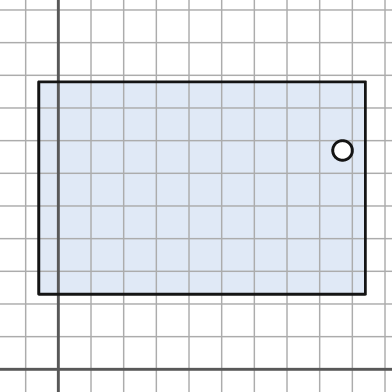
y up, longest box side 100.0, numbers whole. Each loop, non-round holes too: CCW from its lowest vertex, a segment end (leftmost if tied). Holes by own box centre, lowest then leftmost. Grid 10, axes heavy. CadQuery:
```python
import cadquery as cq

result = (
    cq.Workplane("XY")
    .moveTo(-6.0, 23.0)
    .lineTo(94.0, 23.0)
    .lineTo(94.0, 88.0)
    .lineTo(-6.0, 88.0)
    .close()
    .moveTo(87.0, 67.0)
    .circle(3.0)
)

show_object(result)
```